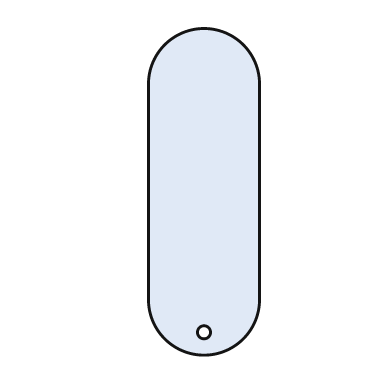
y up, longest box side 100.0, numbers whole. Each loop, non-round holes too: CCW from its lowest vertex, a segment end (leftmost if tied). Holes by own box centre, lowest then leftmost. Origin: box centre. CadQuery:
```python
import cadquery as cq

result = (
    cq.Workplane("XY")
    .moveTo(-17.0, -33.0)
    .threePointArc((0.0, -50.0), (17.0, -33.0))
    .lineTo(17.0, 33.0)
    .threePointArc((0.0, 50.0), (-17.0, 33.0))
    .close()
    .moveTo(0.0, -43.0)
    .circle(2.0)
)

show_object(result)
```